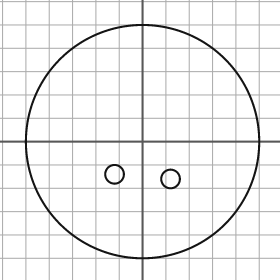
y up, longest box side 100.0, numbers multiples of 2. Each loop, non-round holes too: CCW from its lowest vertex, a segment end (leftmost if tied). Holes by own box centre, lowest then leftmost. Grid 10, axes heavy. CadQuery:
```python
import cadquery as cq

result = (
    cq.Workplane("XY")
    .moveTo(0.0, 0.0)
    .circle(50.0)
    .moveTo(12.0, -16.0)
    .circle(4.0)
    .moveTo(-12.0, -14.0)
    .circle(4.0)
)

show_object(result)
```